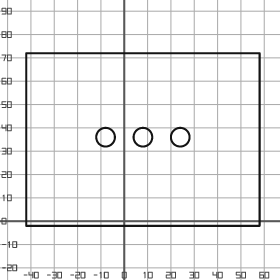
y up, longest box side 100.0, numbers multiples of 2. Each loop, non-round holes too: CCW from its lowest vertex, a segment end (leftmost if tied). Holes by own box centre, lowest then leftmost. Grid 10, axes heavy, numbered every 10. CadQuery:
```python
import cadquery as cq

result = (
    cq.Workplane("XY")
    .moveTo(-42.0, -2.0)
    .lineTo(58.0, -2.0)
    .lineTo(58.0, 72.0)
    .lineTo(-42.0, 72.0)
    .close()
    .moveTo(-8.0, 36.0)
    .circle(4.0)
    .moveTo(8.0, 36.0)
    .circle(4.0)
    .moveTo(24.0, 36.0)
    .circle(4.0)
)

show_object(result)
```